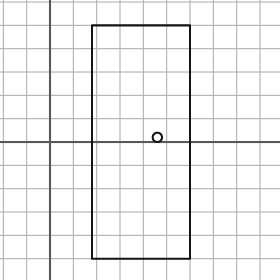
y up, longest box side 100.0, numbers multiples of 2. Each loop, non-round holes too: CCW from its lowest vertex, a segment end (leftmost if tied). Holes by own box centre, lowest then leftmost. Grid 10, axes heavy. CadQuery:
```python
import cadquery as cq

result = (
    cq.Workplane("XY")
    .moveTo(18.0, -50.0)
    .lineTo(60.0, -50.0)
    .lineTo(60.0, 50.0)
    .lineTo(18.0, 50.0)
    .close()
    .moveTo(46.0, 2.0)
    .circle(2.0)
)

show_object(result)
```